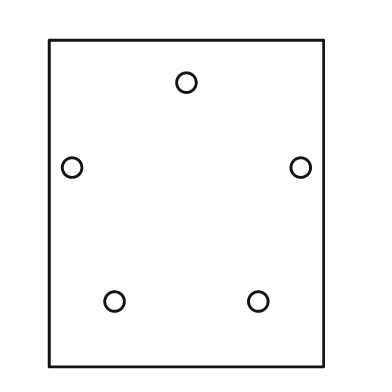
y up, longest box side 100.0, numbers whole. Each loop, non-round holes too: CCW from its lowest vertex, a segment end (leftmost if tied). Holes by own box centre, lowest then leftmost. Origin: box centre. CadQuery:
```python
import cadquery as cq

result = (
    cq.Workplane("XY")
    .moveTo(-42.0, -50.0)
    .lineTo(42.0, -50.0)
    .lineTo(42.0, 50.0)
    .lineTo(-42.0, 50.0)
    .close()
    .moveTo(-22.0, -30.0)
    .circle(3.0)
    .moveTo(22.0, -30.0)
    .circle(3.0)
    .moveTo(-35.0, 11.0)
    .circle(3.0)
    .moveTo(35.0, 11.0)
    .circle(3.0)
    .moveTo(0.0, 37.0)
    .circle(3.0)
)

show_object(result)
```